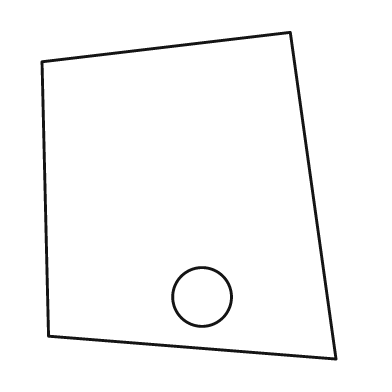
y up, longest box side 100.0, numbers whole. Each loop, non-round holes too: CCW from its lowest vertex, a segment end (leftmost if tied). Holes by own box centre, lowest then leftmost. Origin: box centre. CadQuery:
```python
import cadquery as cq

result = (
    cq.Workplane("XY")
    .moveTo(45.0, -50.0)
    .lineTo(31.0, 50.0)
    .lineTo(-45.0, 41.0)
    .lineTo(-43.0, -43.0)
    .close()
    .moveTo(4.0, -31.0)
    .circle(9.0)
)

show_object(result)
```